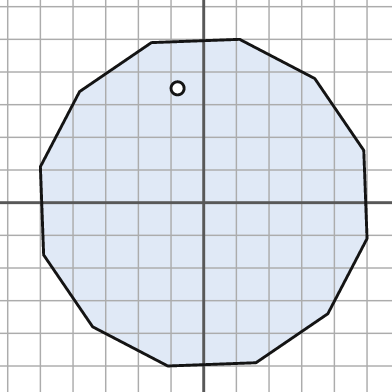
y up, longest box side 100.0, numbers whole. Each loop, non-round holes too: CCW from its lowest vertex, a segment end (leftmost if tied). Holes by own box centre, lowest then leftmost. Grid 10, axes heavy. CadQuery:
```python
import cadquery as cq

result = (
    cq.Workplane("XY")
    .moveTo(-11.0, -50.0)
    .lineTo(16.0, -49.0)
    .lineTo(38.0, -34.0)
    .lineTo(50.0, -11.0)
    .lineTo(49.0, 16.0)
    .lineTo(34.0, 38.0)
    .lineTo(11.0, 50.0)
    .lineTo(-16.0, 49.0)
    .lineTo(-38.0, 34.0)
    .lineTo(-50.0, 11.0)
    .lineTo(-49.0, -16.0)
    .lineTo(-34.0, -38.0)
    .close()
    .moveTo(-8.0, 35.0)
    .circle(2.0)
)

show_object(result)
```